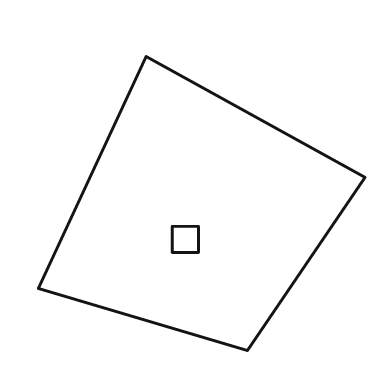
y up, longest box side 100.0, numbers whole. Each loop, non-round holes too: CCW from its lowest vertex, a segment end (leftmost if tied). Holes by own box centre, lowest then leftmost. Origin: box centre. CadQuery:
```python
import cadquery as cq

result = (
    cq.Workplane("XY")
    .moveTo(14.0, -45.0)
    .lineTo(50.0, 8.0)
    .lineTo(-17.0, 45.0)
    .lineTo(-50.0, -26.0)
    .close()
    .moveTo(-9.0, -15.0)
    .lineTo(-1.0, -15.0)
    .lineTo(-1.0, -7.0)
    .lineTo(-9.0, -7.0)
    .close()
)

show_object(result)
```